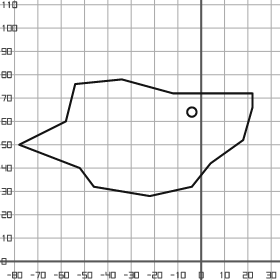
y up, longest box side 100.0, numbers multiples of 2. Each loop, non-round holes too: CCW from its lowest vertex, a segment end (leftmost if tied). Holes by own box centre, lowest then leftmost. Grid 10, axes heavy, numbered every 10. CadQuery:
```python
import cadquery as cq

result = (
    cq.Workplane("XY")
    .moveTo(-22.0, 28.0)
    .lineTo(-4.0, 32.0)
    .lineTo(4.0, 42.0)
    .lineTo(18.0, 52.0)
    .lineTo(22.0, 66.0)
    .lineTo(22.0, 72.0)
    .lineTo(-12.0, 72.0)
    .lineTo(-34.0, 78.0)
    .lineTo(-54.0, 76.0)
    .lineTo(-58.0, 60.0)
    .lineTo(-78.0, 50.0)
    .lineTo(-52.0, 40.0)
    .lineTo(-46.0, 32.0)
    .close()
    .moveTo(-4.0, 64.0)
    .circle(2.0)
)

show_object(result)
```